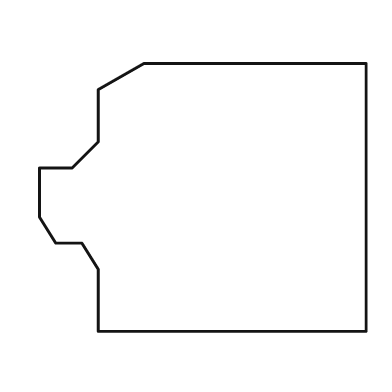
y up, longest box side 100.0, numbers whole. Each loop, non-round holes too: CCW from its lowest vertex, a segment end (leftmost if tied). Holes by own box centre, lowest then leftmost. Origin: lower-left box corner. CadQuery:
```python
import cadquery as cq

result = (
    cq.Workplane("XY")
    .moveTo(18.0, 0.0)
    .lineTo(100.0, 0.0)
    .lineTo(100.0, 82.0)
    .lineTo(32.0, 82.0)
    .lineTo(18.0, 74.0)
    .lineTo(18.0, 58.0)
    .lineTo(10.0, 50.0)
    .lineTo(0.0, 50.0)
    .lineTo(0.0, 35.0)
    .lineTo(5.0, 27.0)
    .lineTo(13.0, 27.0)
    .lineTo(18.0, 19.0)
    .close()
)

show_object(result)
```